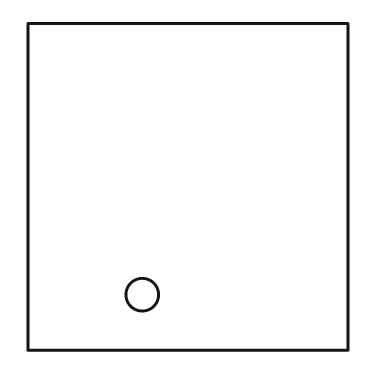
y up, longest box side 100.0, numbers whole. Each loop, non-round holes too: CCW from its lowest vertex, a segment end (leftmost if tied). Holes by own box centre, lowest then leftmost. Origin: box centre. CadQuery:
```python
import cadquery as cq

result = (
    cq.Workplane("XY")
    .moveTo(-49.0, -50.0)
    .lineTo(49.0, -50.0)
    .lineTo(49.0, 50.0)
    .lineTo(-49.0, 50.0)
    .close()
    .moveTo(-14.0, -33.0)
    .circle(5.0)
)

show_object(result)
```